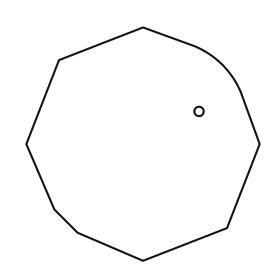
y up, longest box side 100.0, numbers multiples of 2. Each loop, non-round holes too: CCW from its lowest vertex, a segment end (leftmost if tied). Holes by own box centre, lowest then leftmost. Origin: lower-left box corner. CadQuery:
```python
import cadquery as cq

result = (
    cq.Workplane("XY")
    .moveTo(50.0, 0.0)
    .lineTo(86.0, 14.0)
    .lineTo(100.0, 50.0)
    .lineTo(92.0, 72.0)
    .threePointArc((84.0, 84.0), (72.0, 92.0))
    .lineTo(50.0, 100.0)
    .lineTo(14.0, 86.0)
    .lineTo(0.0, 50.0)
    .lineTo(12.0, 22.0)
    .lineTo(22.0, 12.0)
    .close()
    .moveTo(74.0, 64.0)
    .circle(2.0)
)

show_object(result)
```